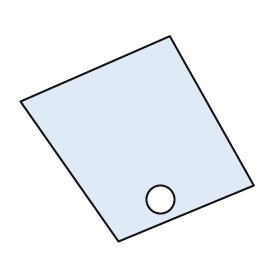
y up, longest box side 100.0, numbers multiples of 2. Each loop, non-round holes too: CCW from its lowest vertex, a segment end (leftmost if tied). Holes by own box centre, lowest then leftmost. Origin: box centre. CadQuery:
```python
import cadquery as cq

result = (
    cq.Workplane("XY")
    .moveTo(-8.0, -44.0)
    .lineTo(50.0, -20.0)
    .lineTo(14.0, 44.0)
    .lineTo(-50.0, 16.0)
    .close()
    .moveTo(10.0, -26.0)
    .circle(6.0)
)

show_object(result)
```